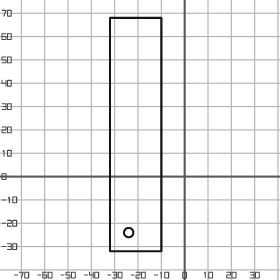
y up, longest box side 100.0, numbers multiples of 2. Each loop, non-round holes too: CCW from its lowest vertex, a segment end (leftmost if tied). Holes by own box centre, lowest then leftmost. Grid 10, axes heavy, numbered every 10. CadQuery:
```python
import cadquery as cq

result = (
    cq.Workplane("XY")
    .moveTo(-32.0, -32.0)
    .lineTo(-10.0, -32.0)
    .lineTo(-10.0, 68.0)
    .lineTo(-32.0, 68.0)
    .close()
    .moveTo(-24.0, -24.0)
    .circle(2.0)
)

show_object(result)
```